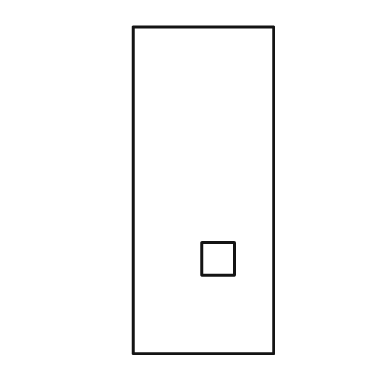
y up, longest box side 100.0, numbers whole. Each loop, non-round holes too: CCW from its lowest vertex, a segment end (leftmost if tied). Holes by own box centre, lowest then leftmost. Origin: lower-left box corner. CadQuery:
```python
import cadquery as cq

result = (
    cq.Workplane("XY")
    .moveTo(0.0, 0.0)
    .lineTo(43.0, 0.0)
    .lineTo(43.0, 100.0)
    .lineTo(0.0, 100.0)
    .close()
    .moveTo(21.0, 24.0)
    .lineTo(31.0, 24.0)
    .lineTo(31.0, 34.0)
    .lineTo(21.0, 34.0)
    .close()
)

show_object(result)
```